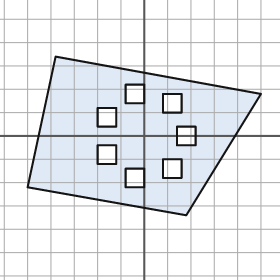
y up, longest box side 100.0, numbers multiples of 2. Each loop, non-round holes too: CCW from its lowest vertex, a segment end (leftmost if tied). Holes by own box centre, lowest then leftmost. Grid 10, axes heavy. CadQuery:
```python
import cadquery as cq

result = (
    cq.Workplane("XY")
    .moveTo(18.0, -34.0)
    .lineTo(50.0, 18.0)
    .lineTo(-38.0, 34.0)
    .lineTo(-50.0, -22.0)
    .close()
    .moveTo(-8.0, -22.0)
    .lineTo(0.0, -22.0)
    .lineTo(0.0, -14.0)
    .lineTo(-8.0, -14.0)
    .close()
    .moveTo(8.0, -18.0)
    .lineTo(16.0, -18.0)
    .lineTo(16.0, -10.0)
    .lineTo(8.0, -10.0)
    .close()
    .moveTo(-20.0, -12.0)
    .lineTo(-12.0, -12.0)
    .lineTo(-12.0, -4.0)
    .lineTo(-20.0, -4.0)
    .close()
    .moveTo(14.0, -4.0)
    .lineTo(22.0, -4.0)
    .lineTo(22.0, 4.0)
    .lineTo(14.0, 4.0)
    .close()
    .moveTo(-20.0, 4.0)
    .lineTo(-12.0, 4.0)
    .lineTo(-12.0, 12.0)
    .lineTo(-20.0, 12.0)
    .close()
    .moveTo(8.0, 10.0)
    .lineTo(16.0, 10.0)
    .lineTo(16.0, 18.0)
    .lineTo(8.0, 18.0)
    .close()
    .moveTo(-8.0, 14.0)
    .lineTo(0.0, 14.0)
    .lineTo(0.0, 22.0)
    .lineTo(-8.0, 22.0)
    .close()
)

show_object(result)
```